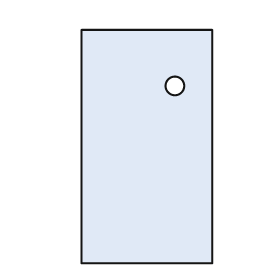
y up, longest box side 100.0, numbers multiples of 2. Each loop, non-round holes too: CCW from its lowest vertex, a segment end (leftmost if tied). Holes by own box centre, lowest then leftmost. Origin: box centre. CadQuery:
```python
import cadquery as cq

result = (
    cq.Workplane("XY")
    .moveTo(-28.0, -50.0)
    .lineTo(28.0, -50.0)
    .lineTo(28.0, 50.0)
    .lineTo(-28.0, 50.0)
    .close()
    .moveTo(12.0, 26.0)
    .circle(4.0)
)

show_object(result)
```